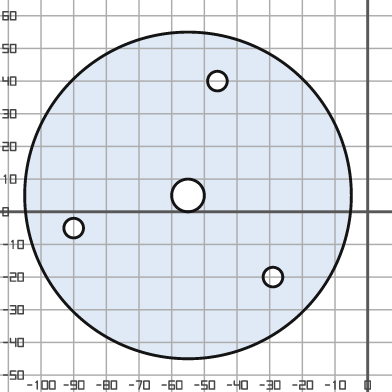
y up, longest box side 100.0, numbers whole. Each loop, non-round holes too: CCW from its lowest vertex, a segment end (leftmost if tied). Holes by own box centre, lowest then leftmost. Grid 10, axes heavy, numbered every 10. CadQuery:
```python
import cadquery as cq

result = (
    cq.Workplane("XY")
    .moveTo(-55.0, 5.0)
    .circle(50.0)
    .moveTo(-29.0, -20.0)
    .circle(3.0)
    .moveTo(-90.0, -5.0)
    .circle(3.0)
    .moveTo(-55.0, 5.0)
    .circle(5.0)
    .moveTo(-46.0, 40.0)
    .circle(3.0)
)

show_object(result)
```